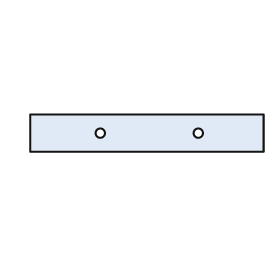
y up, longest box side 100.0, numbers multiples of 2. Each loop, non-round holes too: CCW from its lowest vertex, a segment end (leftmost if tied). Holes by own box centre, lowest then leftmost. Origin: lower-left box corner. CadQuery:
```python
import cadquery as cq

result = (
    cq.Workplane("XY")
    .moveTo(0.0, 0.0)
    .lineTo(100.0, 0.0)
    .lineTo(100.0, 16.0)
    .lineTo(0.0, 16.0)
    .close()
    .moveTo(30.0, 8.0)
    .circle(2.0)
    .moveTo(72.0, 8.0)
    .circle(2.0)
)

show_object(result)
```